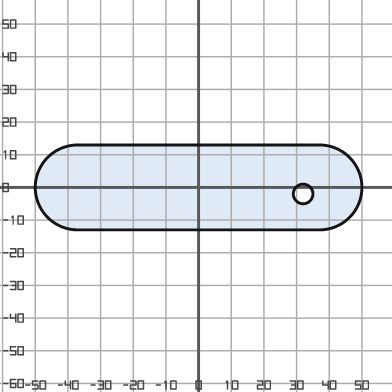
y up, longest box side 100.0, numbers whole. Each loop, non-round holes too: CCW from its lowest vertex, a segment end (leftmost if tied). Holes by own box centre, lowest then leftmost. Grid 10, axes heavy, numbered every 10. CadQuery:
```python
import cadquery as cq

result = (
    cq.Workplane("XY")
    .moveTo(-37.0, -13.0)
    .lineTo(37.0, -13.0)
    .threePointArc((50.0, 0.0), (37.0, 13.0))
    .lineTo(-37.0, 13.0)
    .threePointArc((-50.0, 0.0), (-37.0, -13.0))
    .close()
    .moveTo(32.0, -2.0)
    .circle(3.0)
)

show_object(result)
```